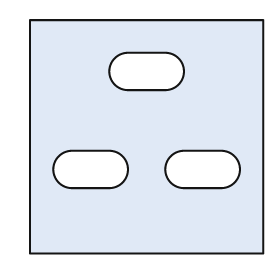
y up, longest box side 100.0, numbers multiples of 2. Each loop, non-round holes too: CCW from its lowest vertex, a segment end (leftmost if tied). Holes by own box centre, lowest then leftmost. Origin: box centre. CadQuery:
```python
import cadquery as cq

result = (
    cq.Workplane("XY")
    .moveTo(-50.0, -50.0)
    .lineTo(50.0, -50.0)
    .lineTo(50.0, 50.0)
    .lineTo(-50.0, 50.0)
    .close()
    .moveTo(-32.0, -22.0)
    .lineTo(-16.0, -22.0)
    .threePointArc((-8.0, -14.0), (-16.0, -6.0))
    .lineTo(-32.0, -6.0)
    .threePointArc((-40.0, -14.0), (-32.0, -22.0))
    .close()
    .moveTo(16.0, -22.0)
    .lineTo(32.0, -22.0)
    .threePointArc((40.0, -14.0), (32.0, -6.0))
    .lineTo(16.0, -6.0)
    .threePointArc((8.0, -14.0), (16.0, -22.0))
    .close()
    .moveTo(-8.0, 20.0)
    .lineTo(8.0, 20.0)
    .threePointArc((16.0, 28.0), (8.0, 36.0))
    .lineTo(-8.0, 36.0)
    .threePointArc((-16.0, 28.0), (-8.0, 20.0))
    .close()
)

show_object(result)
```